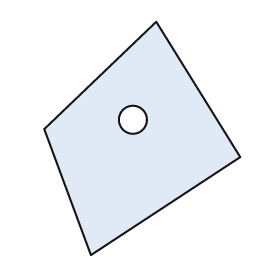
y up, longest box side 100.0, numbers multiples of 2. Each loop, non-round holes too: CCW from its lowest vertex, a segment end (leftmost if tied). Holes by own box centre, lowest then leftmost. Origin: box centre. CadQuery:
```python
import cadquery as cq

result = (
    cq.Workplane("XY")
    .moveTo(-22.0, -50.0)
    .lineTo(42.0, -8.0)
    .lineTo(6.0, 50.0)
    .lineTo(-42.0, 4.0)
    .close()
    .moveTo(-4.0, 8.0)
    .circle(6.0)
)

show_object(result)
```